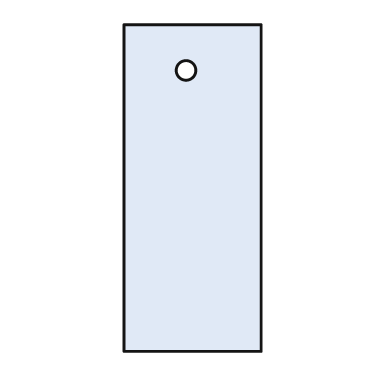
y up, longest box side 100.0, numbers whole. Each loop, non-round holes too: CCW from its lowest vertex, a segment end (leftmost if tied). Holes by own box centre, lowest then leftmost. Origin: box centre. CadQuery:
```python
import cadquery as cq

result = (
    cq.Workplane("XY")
    .moveTo(-21.0, -50.0)
    .lineTo(21.0, -50.0)
    .lineTo(21.0, 50.0)
    .lineTo(-21.0, 50.0)
    .close()
    .moveTo(-2.0, 36.0)
    .circle(3.0)
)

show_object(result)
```